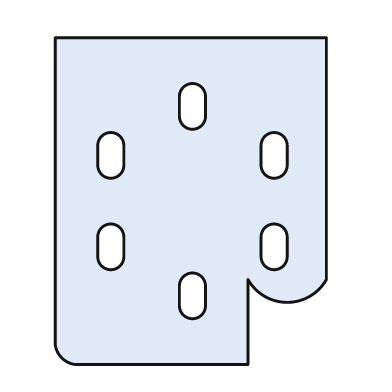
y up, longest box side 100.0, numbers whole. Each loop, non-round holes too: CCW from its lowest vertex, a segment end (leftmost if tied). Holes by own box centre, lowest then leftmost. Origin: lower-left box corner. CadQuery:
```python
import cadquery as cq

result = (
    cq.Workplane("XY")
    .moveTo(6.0, 0.0)
    .lineTo(59.0, 0.0)
    .lineTo(59.0, 26.0)
    .threePointArc((71.0, 19.0), (83.0, 26.0))
    .lineTo(83.0, 100.0)
    .lineTo(0.0, 100.0)
    .lineTo(0.0, 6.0)
    .threePointArc((2.0, 2.0), (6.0, 0.0))
    .close()
    .moveTo(38.0, 18.0)
    .threePointArc((42.0, 14.0), (46.0, 18.0))
    .lineTo(46.0, 24.0)
    .threePointArc((42.0, 28.0), (38.0, 24.0))
    .close()
    .moveTo(13.0, 33.0)
    .threePointArc((17.0, 29.0), (21.0, 33.0))
    .lineTo(21.0, 39.0)
    .threePointArc((17.0, 43.0), (13.0, 39.0))
    .close()
    .moveTo(63.0, 33.0)
    .threePointArc((67.0, 29.0), (71.0, 33.0))
    .lineTo(71.0, 39.0)
    .threePointArc((67.0, 43.0), (63.0, 39.0))
    .close()
    .moveTo(13.0, 61.0)
    .threePointArc((17.0, 57.0), (21.0, 61.0))
    .lineTo(21.0, 67.0)
    .threePointArc((17.0, 71.0), (13.0, 67.0))
    .close()
    .moveTo(63.0, 61.0)
    .threePointArc((67.0, 57.0), (71.0, 61.0))
    .lineTo(71.0, 67.0)
    .threePointArc((67.0, 71.0), (63.0, 67.0))
    .close()
    .moveTo(38.0, 76.0)
    .threePointArc((42.0, 72.0), (46.0, 76.0))
    .lineTo(46.0, 82.0)
    .threePointArc((42.0, 86.0), (38.0, 82.0))
    .close()
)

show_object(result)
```